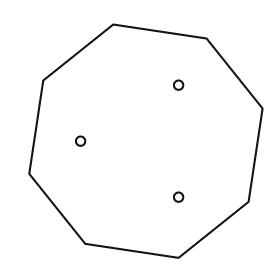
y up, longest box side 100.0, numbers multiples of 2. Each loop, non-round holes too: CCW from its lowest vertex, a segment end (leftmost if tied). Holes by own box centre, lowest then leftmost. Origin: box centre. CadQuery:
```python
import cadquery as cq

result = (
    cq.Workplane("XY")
    .moveTo(14.0, -50.0)
    .lineTo(44.0, -26.0)
    .lineTo(50.0, 14.0)
    .lineTo(26.0, 44.0)
    .lineTo(-14.0, 50.0)
    .lineTo(-44.0, 26.0)
    .lineTo(-50.0, -14.0)
    .lineTo(-26.0, -44.0)
    .close()
    .moveTo(14.0, -24.0)
    .circle(2.0)
    .moveTo(-28.0, 0.0)
    .circle(2.0)
    .moveTo(14.0, 24.0)
    .circle(2.0)
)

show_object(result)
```